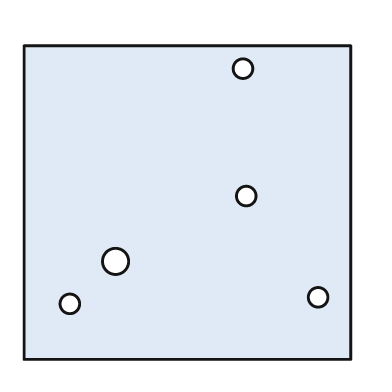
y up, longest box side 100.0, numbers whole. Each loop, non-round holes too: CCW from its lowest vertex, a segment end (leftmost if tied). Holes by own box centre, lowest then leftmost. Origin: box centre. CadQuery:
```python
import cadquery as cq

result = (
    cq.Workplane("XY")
    .moveTo(-50.0, -48.0)
    .lineTo(50.0, -48.0)
    .lineTo(50.0, 48.0)
    .lineTo(-50.0, 48.0)
    .close()
    .moveTo(-36.0, -31.0)
    .circle(3.0)
    .moveTo(40.0, -29.0)
    .circle(3.0)
    .moveTo(-22.0, -18.0)
    .circle(4.0)
    .moveTo(18.0, 2.0)
    .circle(3.0)
    .moveTo(17.0, 41.0)
    .circle(3.0)
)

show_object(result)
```